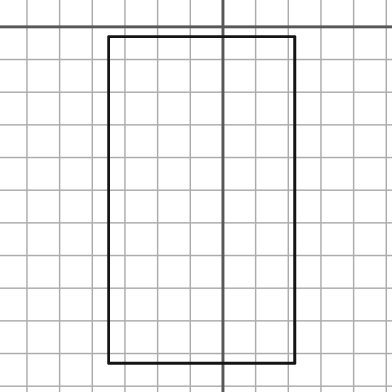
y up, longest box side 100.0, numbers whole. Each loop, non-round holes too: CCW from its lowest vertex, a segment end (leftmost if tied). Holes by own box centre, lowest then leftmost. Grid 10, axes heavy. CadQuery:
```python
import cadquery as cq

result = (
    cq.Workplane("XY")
    .moveTo(-35.0, -103.0)
    .lineTo(22.0, -103.0)
    .lineTo(22.0, -3.0)
    .lineTo(-35.0, -3.0)
    .close()
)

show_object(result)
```